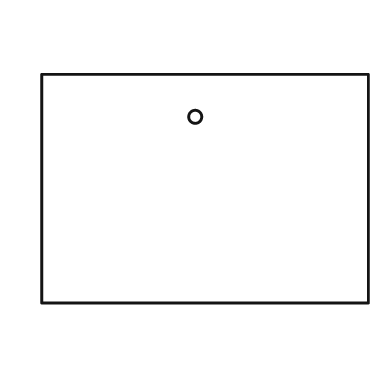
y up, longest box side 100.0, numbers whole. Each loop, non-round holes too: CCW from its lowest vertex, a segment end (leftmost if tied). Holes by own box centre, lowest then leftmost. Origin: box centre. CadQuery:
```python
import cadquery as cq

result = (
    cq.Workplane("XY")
    .moveTo(-50.0, -35.0)
    .lineTo(50.0, -35.0)
    .lineTo(50.0, 35.0)
    .lineTo(-50.0, 35.0)
    .close()
    .moveTo(-3.0, 22.0)
    .circle(2.0)
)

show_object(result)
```